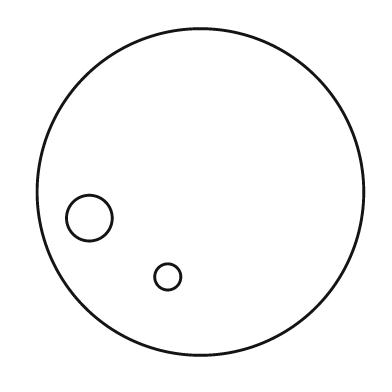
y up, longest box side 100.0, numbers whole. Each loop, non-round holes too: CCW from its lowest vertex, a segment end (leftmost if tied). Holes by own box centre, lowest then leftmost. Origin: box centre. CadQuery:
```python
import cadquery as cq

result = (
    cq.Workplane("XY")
    .moveTo(0.0, 0.0)
    .circle(50.0)
    .moveTo(-10.0, -26.0)
    .circle(4.0)
    .moveTo(-34.0, -8.0)
    .circle(7.0)
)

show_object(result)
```